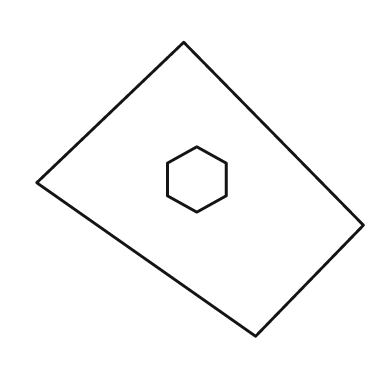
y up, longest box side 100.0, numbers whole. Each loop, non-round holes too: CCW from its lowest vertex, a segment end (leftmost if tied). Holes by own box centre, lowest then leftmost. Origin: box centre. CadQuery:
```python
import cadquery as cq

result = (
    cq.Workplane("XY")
    .moveTo(17.0, -45.0)
    .lineTo(50.0, -11.0)
    .lineTo(-5.0, 45.0)
    .lineTo(-50.0, 2.0)
    .close()
    .moveTo(-1.0, -7.0)
    .lineTo(8.0, -2.0)
    .lineTo(8.0, 8.0)
    .lineTo(-1.0, 13.0)
    .lineTo(-10.0, 8.0)
    .lineTo(-10.0, -2.0)
    .close()
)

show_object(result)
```